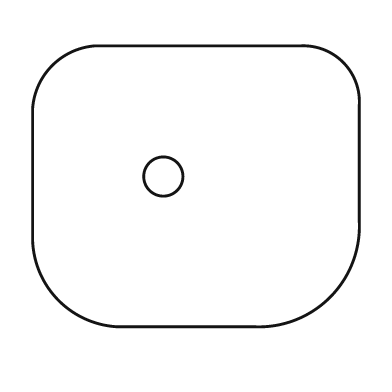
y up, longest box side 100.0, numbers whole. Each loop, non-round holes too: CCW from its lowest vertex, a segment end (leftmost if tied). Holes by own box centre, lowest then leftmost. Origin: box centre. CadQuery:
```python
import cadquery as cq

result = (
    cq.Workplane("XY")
    .moveTo(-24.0, -43.0)
    .lineTo(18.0, -43.0)
    .threePointArc((41.0, -34.0), (50.0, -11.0))
    .lineTo(50.0, 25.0)
    .threePointArc((45.0, 38.0), (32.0, 43.0))
    .lineTo(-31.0, 43.0)
    .threePointArc((-44.0, 37.0), (-50.0, 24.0))
    .lineTo(-50.0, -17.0)
    .threePointArc((-42.0, -35.0), (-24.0, -43.0))
    .close()
    .moveTo(-10.0, 3.0)
    .circle(6.0)
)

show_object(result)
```